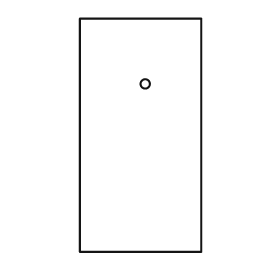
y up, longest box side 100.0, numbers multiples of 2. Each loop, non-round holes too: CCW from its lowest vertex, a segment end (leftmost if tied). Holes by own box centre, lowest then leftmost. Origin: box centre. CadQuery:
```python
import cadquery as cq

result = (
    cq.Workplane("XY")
    .moveTo(-26.0, -50.0)
    .lineTo(26.0, -50.0)
    .lineTo(26.0, 50.0)
    .lineTo(-26.0, 50.0)
    .close()
    .moveTo(2.0, 22.0)
    .circle(2.0)
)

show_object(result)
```